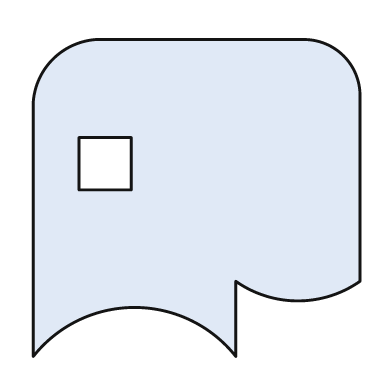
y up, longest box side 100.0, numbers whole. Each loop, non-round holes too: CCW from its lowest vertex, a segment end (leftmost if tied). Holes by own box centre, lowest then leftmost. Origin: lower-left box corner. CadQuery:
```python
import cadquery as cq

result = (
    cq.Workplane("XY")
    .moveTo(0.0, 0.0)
    .threePointArc((31.0, 15.0), (62.0, 0.0))
    .lineTo(62.0, 23.0)
    .threePointArc((81.0, 17.0), (100.0, 23.0))
    .lineTo(100.0, 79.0)
    .threePointArc((95.0, 92.0), (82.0, 97.0))
    .lineTo(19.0, 97.0)
    .threePointArc((6.0, 91.0), (0.0, 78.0))
    .close()
    .moveTo(14.0, 51.0)
    .lineTo(30.0, 51.0)
    .lineTo(30.0, 67.0)
    .lineTo(14.0, 67.0)
    .close()
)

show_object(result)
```